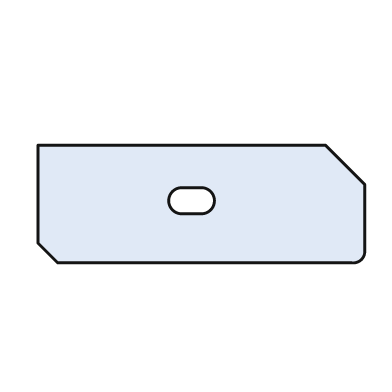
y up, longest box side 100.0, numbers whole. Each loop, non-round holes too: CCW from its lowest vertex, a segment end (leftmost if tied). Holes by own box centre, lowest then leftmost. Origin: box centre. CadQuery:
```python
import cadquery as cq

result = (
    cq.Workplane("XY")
    .moveTo(-44.0, -18.0)
    .lineTo(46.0, -18.0)
    .threePointArc((49.0, -17.0), (50.0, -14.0))
    .lineTo(50.0, 6.0)
    .lineTo(38.0, 18.0)
    .lineTo(-50.0, 18.0)
    .lineTo(-50.0, -12.0)
    .close()
    .moveTo(-6.0, -3.0)
    .lineTo(0.0, -3.0)
    .threePointArc((4.0, 1.0), (0.0, 5.0))
    .lineTo(-6.0, 5.0)
    .threePointArc((-10.0, 1.0), (-6.0, -3.0))
    .close()
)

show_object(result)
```